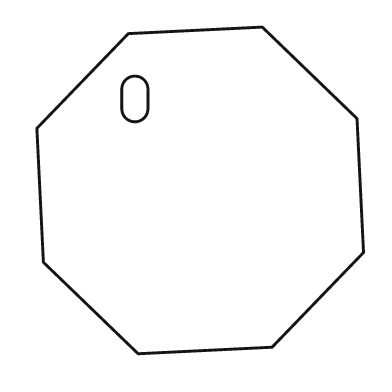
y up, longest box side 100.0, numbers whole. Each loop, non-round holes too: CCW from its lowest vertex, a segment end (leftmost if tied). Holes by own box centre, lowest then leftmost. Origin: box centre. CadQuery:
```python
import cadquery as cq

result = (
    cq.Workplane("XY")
    .moveTo(-19.0, -50.0)
    .lineTo(22.0, -48.0)
    .lineTo(50.0, -19.0)
    .lineTo(48.0, 22.0)
    .lineTo(19.0, 50.0)
    .lineTo(-22.0, 48.0)
    .lineTo(-50.0, 19.0)
    .lineTo(-48.0, -22.0)
    .close()
    .moveTo(-24.0, 25.0)
    .threePointArc((-20.0, 21.0), (-16.0, 25.0))
    .lineTo(-16.0, 31.0)
    .threePointArc((-20.0, 35.0), (-24.0, 31.0))
    .close()
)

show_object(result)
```